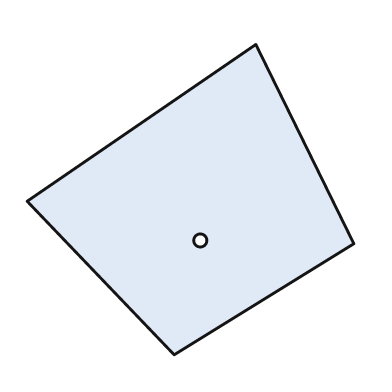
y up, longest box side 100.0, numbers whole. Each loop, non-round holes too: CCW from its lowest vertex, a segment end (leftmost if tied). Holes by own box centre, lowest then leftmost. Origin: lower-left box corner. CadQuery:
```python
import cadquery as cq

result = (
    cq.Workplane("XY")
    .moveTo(45.0, 0.0)
    .lineTo(100.0, 34.0)
    .lineTo(70.0, 95.0)
    .lineTo(0.0, 47.0)
    .close()
    .moveTo(53.0, 35.0)
    .circle(2.0)
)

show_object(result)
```